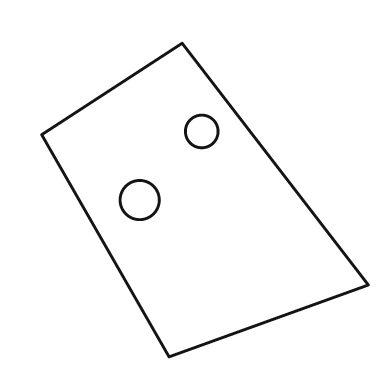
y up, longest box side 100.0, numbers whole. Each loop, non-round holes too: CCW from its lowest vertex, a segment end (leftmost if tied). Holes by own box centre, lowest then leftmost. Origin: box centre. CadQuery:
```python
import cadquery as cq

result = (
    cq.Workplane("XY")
    .moveTo(-11.0, -48.0)
    .lineTo(50.0, -26.0)
    .lineTo(-7.0, 48.0)
    .lineTo(-50.0, 20.0)
    .close()
    .moveTo(-20.0, 0.0)
    .circle(6.0)
    .moveTo(-1.0, 21.0)
    .circle(5.0)
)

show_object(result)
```